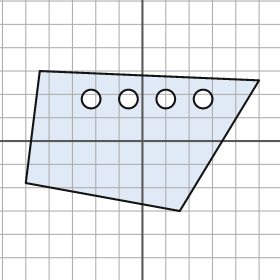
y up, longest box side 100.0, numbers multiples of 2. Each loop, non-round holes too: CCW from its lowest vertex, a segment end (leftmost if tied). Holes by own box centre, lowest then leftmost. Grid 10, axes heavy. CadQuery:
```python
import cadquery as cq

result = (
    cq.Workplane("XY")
    .moveTo(16.0, -30.0)
    .lineTo(50.0, 26.0)
    .lineTo(-44.0, 30.0)
    .lineTo(-50.0, -18.0)
    .close()
    .moveTo(-22.0, 18.0)
    .circle(4.0)
    .moveTo(-6.0, 18.0)
    .circle(4.0)
    .moveTo(10.0, 18.0)
    .circle(4.0)
    .moveTo(26.0, 18.0)
    .circle(4.0)
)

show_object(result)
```